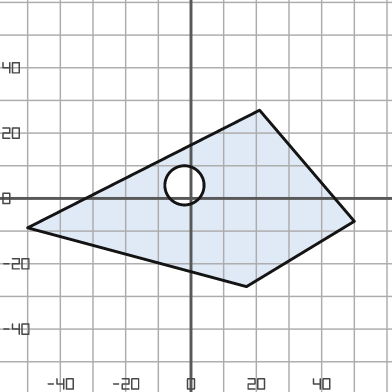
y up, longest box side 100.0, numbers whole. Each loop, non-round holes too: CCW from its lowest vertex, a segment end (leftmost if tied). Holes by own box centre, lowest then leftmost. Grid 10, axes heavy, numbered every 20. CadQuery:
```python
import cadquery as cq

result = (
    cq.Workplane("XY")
    .moveTo(17.0, -27.0)
    .lineTo(50.0, -7.0)
    .lineTo(21.0, 27.0)
    .lineTo(-50.0, -9.0)
    .close()
    .moveTo(-2.0, 4.0)
    .circle(6.0)
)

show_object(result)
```